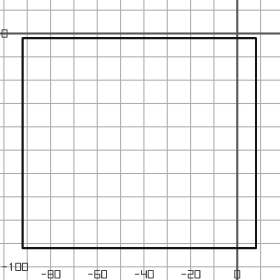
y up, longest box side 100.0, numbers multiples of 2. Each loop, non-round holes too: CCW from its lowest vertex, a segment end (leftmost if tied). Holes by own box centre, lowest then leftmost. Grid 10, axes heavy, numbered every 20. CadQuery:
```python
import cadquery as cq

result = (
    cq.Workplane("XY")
    .moveTo(-92.0, -92.0)
    .lineTo(8.0, -92.0)
    .lineTo(8.0, -2.0)
    .lineTo(-92.0, -2.0)
    .close()
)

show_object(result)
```